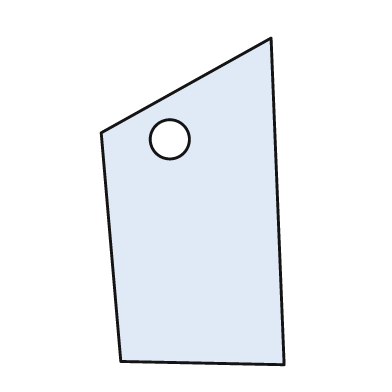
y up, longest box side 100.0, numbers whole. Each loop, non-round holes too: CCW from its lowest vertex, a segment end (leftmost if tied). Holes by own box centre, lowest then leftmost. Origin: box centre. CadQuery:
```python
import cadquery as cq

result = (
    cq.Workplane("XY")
    .moveTo(28.0, -50.0)
    .lineTo(24.0, 50.0)
    .lineTo(-28.0, 21.0)
    .lineTo(-22.0, -49.0)
    .close()
    .moveTo(-7.0, 19.0)
    .circle(6.0)
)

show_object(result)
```